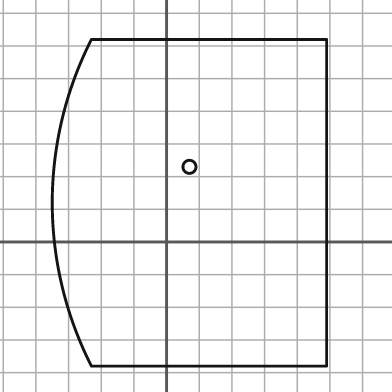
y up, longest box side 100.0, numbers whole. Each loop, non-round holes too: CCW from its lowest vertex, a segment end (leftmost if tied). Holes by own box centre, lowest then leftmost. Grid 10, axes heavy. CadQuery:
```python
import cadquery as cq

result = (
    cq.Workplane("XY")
    .moveTo(-23.0, -38.0)
    .lineTo(49.0, -38.0)
    .lineTo(49.0, 62.0)
    .lineTo(-23.0, 62.0)
    .threePointArc((-35.0, 12.0), (-23.0, -38.0))
    .close()
    .moveTo(7.0, 23.0)
    .circle(2.0)
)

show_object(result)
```